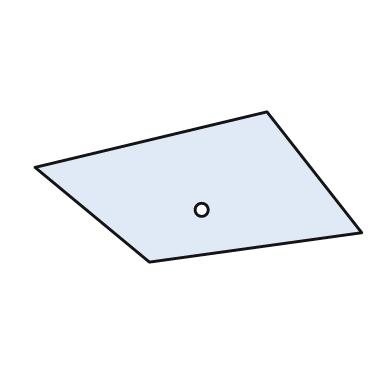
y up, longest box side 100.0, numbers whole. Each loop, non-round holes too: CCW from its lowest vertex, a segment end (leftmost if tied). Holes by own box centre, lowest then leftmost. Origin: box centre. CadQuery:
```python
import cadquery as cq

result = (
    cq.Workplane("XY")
    .moveTo(-15.0, -23.0)
    .lineTo(50.0, -14.0)
    .lineTo(21.0, 23.0)
    .lineTo(-50.0, 6.0)
    .close()
    .moveTo(1.0, -7.0)
    .circle(2.0)
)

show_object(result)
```